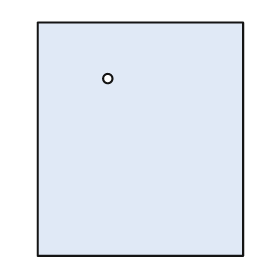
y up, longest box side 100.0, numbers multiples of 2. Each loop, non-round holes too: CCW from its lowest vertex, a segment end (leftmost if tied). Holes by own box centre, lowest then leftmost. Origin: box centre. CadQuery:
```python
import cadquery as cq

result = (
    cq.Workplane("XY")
    .moveTo(-44.0, -50.0)
    .lineTo(44.0, -50.0)
    .lineTo(44.0, 50.0)
    .lineTo(-44.0, 50.0)
    .close()
    .moveTo(-14.0, 26.0)
    .circle(2.0)
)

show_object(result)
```